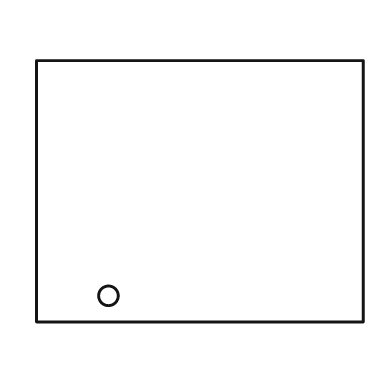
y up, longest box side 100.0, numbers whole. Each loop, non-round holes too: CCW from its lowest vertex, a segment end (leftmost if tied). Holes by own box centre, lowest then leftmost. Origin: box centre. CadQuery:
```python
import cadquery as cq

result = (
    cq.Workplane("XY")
    .moveTo(-50.0, -40.0)
    .lineTo(50.0, -40.0)
    .lineTo(50.0, 40.0)
    .lineTo(-50.0, 40.0)
    .close()
    .moveTo(-28.0, -32.0)
    .circle(3.0)
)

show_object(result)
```